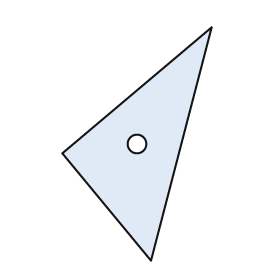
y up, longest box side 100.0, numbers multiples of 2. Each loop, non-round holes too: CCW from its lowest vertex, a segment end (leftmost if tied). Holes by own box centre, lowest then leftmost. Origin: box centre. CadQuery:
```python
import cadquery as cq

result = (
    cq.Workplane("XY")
    .moveTo(6.0, -50.0)
    .lineTo(32.0, 50.0)
    .lineTo(-32.0, -4.0)
    .close()
    .moveTo(0.0, 0.0)
    .circle(4.0)
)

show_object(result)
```